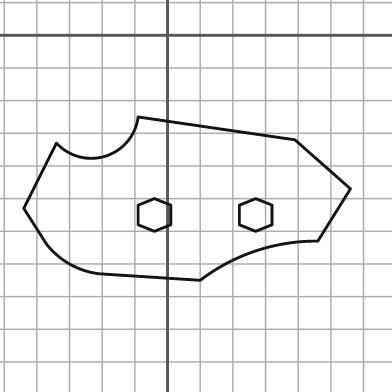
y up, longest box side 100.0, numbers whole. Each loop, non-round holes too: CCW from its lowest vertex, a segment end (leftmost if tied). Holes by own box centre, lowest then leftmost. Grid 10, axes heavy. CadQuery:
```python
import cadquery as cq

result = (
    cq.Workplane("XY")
    .moveTo(10.0, -75.0)
    .threePointArc((27.0, -66.0), (46.0, -63.0))
    .lineTo(56.0, -47.0)
    .lineTo(39.0, -32.0)
    .lineTo(-9.0, -25.0)
    .threePointArc((-19.0, -37.0), (-34.0, -33.0))
    .lineTo(-44.0, -53.0)
    .lineTo(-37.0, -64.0)
    .threePointArc((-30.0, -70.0), (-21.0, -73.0))
    .close()
    .moveTo(-4.0, -60.0)
    .lineTo(1.0, -58.0)
    .lineTo(1.0, -52.0)
    .lineTo(-4.0, -50.0)
    .lineTo(-9.0, -52.0)
    .lineTo(-9.0, -58.0)
    .close()
    .moveTo(27.0, -60.0)
    .lineTo(32.0, -58.0)
    .lineTo(32.0, -52.0)
    .lineTo(27.0, -50.0)
    .lineTo(22.0, -52.0)
    .lineTo(22.0, -58.0)
    .close()
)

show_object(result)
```